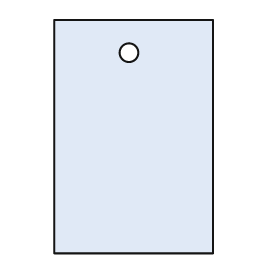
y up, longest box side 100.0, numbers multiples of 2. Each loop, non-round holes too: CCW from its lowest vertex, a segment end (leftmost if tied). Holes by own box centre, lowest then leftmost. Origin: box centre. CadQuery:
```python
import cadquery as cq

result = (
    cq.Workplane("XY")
    .moveTo(-34.0, -50.0)
    .lineTo(34.0, -50.0)
    .lineTo(34.0, 50.0)
    .lineTo(-34.0, 50.0)
    .close()
    .moveTo(-2.0, 36.0)
    .circle(4.0)
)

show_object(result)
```